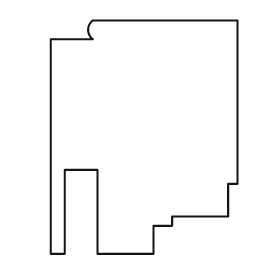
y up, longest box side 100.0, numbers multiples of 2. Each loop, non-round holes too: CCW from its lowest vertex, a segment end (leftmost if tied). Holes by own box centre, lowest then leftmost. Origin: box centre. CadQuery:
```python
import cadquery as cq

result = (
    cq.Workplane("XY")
    .moveTo(-40.0, -50.0)
    .lineTo(-34.0, -50.0)
    .lineTo(-34.0, -14.0)
    .lineTo(-20.0, -14.0)
    .lineTo(-20.0, -50.0)
    .lineTo(4.0, -50.0)
    .lineTo(4.0, -38.0)
    .lineTo(12.0, -38.0)
    .lineTo(12.0, -34.0)
    .lineTo(36.0, -34.0)
    .lineTo(36.0, -20.0)
    .lineTo(40.0, -20.0)
    .lineTo(40.0, 50.0)
    .lineTo(-22.0, 50.0)
    .threePointArc((-24.0, 46.0), (-22.0, 42.0))
    .lineTo(-40.0, 42.0)
    .close()
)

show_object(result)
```